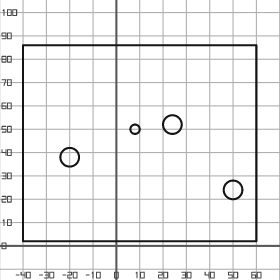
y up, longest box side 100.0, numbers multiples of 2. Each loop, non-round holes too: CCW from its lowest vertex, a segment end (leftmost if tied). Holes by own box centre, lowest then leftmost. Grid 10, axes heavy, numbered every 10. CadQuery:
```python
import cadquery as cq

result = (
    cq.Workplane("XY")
    .moveTo(-40.0, 2.0)
    .lineTo(60.0, 2.0)
    .lineTo(60.0, 86.0)
    .lineTo(-40.0, 86.0)
    .close()
    .moveTo(50.0, 24.0)
    .circle(4.0)
    .moveTo(-20.0, 38.0)
    .circle(4.0)
    .moveTo(8.0, 50.0)
    .circle(2.0)
    .moveTo(24.0, 52.0)
    .circle(4.0)
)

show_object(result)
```